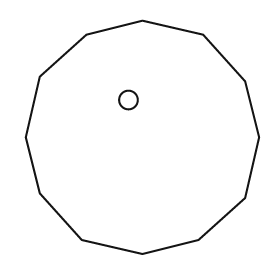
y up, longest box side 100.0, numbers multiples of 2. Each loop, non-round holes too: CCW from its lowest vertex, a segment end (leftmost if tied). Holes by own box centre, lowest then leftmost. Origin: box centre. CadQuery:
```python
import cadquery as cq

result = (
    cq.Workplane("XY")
    .moveTo(0.0, -50.0)
    .lineTo(24.0, -44.0)
    .lineTo(44.0, -26.0)
    .lineTo(50.0, 0.0)
    .lineTo(44.0, 24.0)
    .lineTo(26.0, 44.0)
    .lineTo(0.0, 50.0)
    .lineTo(-24.0, 44.0)
    .lineTo(-44.0, 26.0)
    .lineTo(-50.0, 0.0)
    .lineTo(-44.0, -24.0)
    .lineTo(-26.0, -44.0)
    .close()
    .moveTo(-6.0, 16.0)
    .circle(4.0)
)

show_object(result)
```